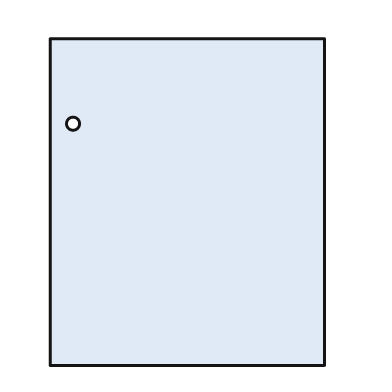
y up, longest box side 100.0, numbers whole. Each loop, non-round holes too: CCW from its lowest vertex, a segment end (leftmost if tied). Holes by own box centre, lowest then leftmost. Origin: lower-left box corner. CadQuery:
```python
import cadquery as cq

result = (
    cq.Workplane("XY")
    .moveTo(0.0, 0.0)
    .lineTo(84.0, 0.0)
    .lineTo(84.0, 100.0)
    .lineTo(0.0, 100.0)
    .close()
    .moveTo(7.0, 74.0)
    .circle(2.0)
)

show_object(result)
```